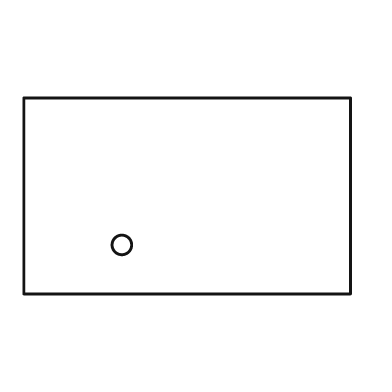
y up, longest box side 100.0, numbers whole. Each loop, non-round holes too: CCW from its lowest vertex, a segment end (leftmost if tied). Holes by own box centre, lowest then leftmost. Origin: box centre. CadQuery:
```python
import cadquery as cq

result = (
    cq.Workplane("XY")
    .moveTo(-50.0, -30.0)
    .lineTo(50.0, -30.0)
    .lineTo(50.0, 30.0)
    .lineTo(-50.0, 30.0)
    .close()
    .moveTo(-20.0, -15.0)
    .circle(3.0)
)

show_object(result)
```